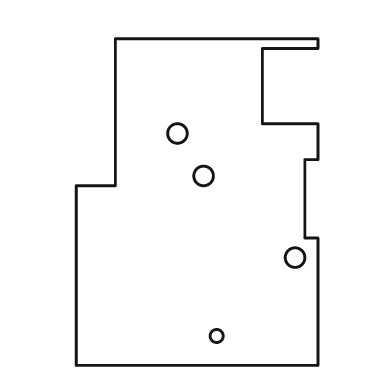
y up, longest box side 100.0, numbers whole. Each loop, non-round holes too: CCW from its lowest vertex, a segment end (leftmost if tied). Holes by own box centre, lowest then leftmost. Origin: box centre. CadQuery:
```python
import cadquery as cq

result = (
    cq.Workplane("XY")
    .moveTo(-37.0, -50.0)
    .lineTo(37.0, -50.0)
    .lineTo(37.0, -11.0)
    .lineTo(33.0, -11.0)
    .lineTo(33.0, 13.0)
    .lineTo(37.0, 13.0)
    .lineTo(37.0, 24.0)
    .lineTo(20.0, 24.0)
    .lineTo(20.0, 47.0)
    .lineTo(37.0, 47.0)
    .lineTo(37.0, 50.0)
    .lineTo(-25.0, 50.0)
    .lineTo(-25.0, 5.0)
    .lineTo(-37.0, 5.0)
    .close()
    .moveTo(6.0, -41.0)
    .circle(2.0)
    .moveTo(30.0, -17.0)
    .circle(3.0)
    .moveTo(2.0, 8.0)
    .circle(3.0)
    .moveTo(-6.0, 21.0)
    .circle(3.0)
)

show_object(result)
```